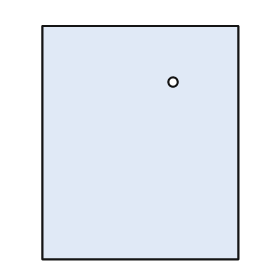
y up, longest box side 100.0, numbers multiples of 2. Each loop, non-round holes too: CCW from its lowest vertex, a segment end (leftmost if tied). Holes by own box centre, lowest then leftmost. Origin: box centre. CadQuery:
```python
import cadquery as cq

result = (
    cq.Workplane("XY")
    .moveTo(-42.0, -50.0)
    .lineTo(42.0, -50.0)
    .lineTo(42.0, 50.0)
    .lineTo(-42.0, 50.0)
    .close()
    .moveTo(14.0, 26.0)
    .circle(2.0)
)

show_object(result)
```